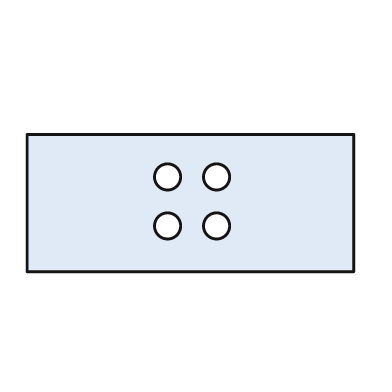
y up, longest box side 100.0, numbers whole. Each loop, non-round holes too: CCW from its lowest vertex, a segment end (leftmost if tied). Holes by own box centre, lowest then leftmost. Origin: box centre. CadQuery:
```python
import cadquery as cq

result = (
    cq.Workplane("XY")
    .moveTo(-50.0, -21.0)
    .lineTo(50.0, -21.0)
    .lineTo(50.0, 21.0)
    .lineTo(-50.0, 21.0)
    .close()
    .moveTo(-7.0, -7.0)
    .circle(4.0)
    .moveTo(8.0, -7.0)
    .circle(4.0)
    .moveTo(-7.0, 8.0)
    .circle(4.0)
    .moveTo(8.0, 8.0)
    .circle(4.0)
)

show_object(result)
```